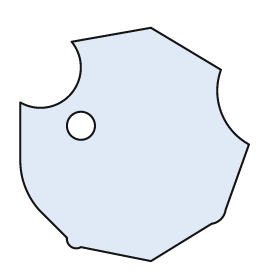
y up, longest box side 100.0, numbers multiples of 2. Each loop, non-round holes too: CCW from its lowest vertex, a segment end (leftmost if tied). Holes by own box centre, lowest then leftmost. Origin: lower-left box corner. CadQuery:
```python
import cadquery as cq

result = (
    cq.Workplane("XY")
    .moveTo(56.0, 0.0)
    .lineTo(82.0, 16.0)
    .threePointArc((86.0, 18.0), (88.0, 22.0))
    .lineTo(98.0, 50.0)
    .threePointArc((86.0, 64.0), (86.0, 82.0))
    .lineTo(56.0, 100.0)
    .lineTo(22.0, 94.0)
    .threePointArc((22.0, 72.0), (0.0, 68.0))
    .lineTo(0.0, 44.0)
    .threePointArc((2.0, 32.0), (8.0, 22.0))
    .lineTo(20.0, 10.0)
    .threePointArc((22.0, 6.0), (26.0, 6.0))
    .close()
    .moveTo(26.0, 58.0)
    .circle(6.0)
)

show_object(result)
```